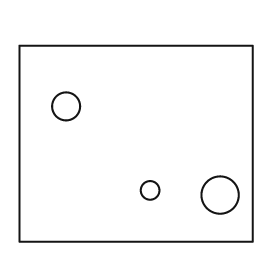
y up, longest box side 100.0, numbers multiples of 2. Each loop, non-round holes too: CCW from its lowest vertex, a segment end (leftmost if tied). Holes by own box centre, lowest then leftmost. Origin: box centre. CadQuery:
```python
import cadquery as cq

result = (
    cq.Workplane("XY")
    .moveTo(-50.0, -42.0)
    .lineTo(50.0, -42.0)
    .lineTo(50.0, 42.0)
    .lineTo(-50.0, 42.0)
    .close()
    .moveTo(36.0, -22.0)
    .circle(8.0)
    .moveTo(6.0, -20.0)
    .circle(4.0)
    .moveTo(-30.0, 16.0)
    .circle(6.0)
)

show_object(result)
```